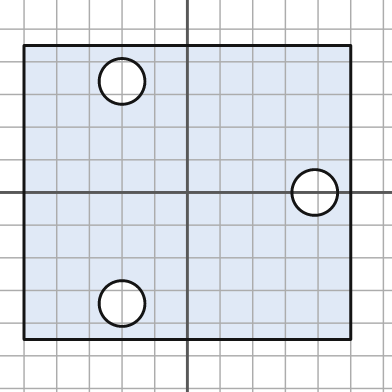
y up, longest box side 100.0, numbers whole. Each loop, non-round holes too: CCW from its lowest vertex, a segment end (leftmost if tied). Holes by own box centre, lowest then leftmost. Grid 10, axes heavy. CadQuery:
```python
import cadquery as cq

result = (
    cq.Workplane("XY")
    .moveTo(-50.0, -45.0)
    .lineTo(50.0, -45.0)
    .lineTo(50.0, 45.0)
    .lineTo(-50.0, 45.0)
    .close()
    .moveTo(-20.0, -34.0)
    .circle(7.0)
    .moveTo(39.0, 0.0)
    .circle(7.0)
    .moveTo(-20.0, 34.0)
    .circle(7.0)
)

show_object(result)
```